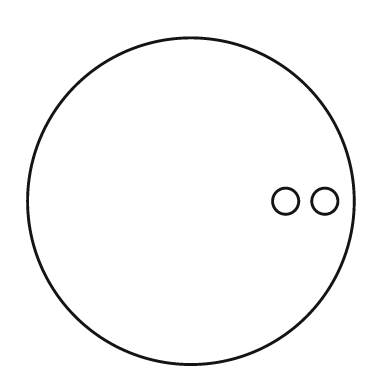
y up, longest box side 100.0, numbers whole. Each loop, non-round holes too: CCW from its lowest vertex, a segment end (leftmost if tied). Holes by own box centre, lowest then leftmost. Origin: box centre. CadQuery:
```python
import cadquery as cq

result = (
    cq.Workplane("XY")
    .moveTo(0.0, 0.0)
    .circle(50.0)
    .moveTo(29.0, 0.0)
    .circle(4.0)
    .moveTo(41.0, 0.0)
    .circle(4.0)
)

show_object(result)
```